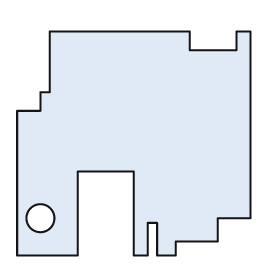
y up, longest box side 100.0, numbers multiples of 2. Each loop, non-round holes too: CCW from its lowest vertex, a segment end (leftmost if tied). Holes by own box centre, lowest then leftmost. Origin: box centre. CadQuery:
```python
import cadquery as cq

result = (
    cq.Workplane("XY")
    .moveTo(-50.0, -48.0)
    .lineTo(-24.0, -48.0)
    .lineTo(-24.0, -12.0)
    .lineTo(0.0, -12.0)
    .lineTo(0.0, -48.0)
    .lineTo(6.0, -48.0)
    .lineTo(6.0, -34.0)
    .lineTo(10.0, -34.0)
    .lineTo(10.0, -48.0)
    .lineTo(18.0, -48.0)
    .lineTo(18.0, -42.0)
    .lineTo(36.0, -42.0)
    .lineTo(36.0, -32.0)
    .lineTo(50.0, -32.0)
    .lineTo(50.0, 48.0)
    .lineTo(44.0, 48.0)
    .lineTo(44.0, 40.0)
    .lineTo(24.0, 40.0)
    .lineTo(24.0, 48.0)
    .lineTo(-36.0, 48.0)
    .lineTo(-36.0, 22.0)
    .lineTo(-40.0, 22.0)
    .lineTo(-40.0, 14.0)
    .lineTo(-50.0, 14.0)
    .close()
    .moveTo(-40.0, -32.0)
    .circle(6.0)
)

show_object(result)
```